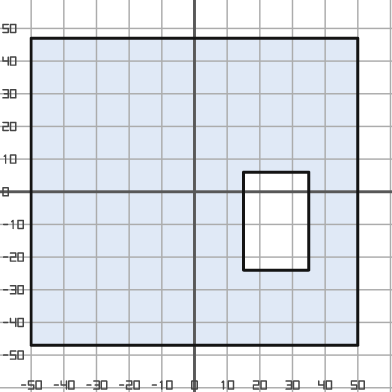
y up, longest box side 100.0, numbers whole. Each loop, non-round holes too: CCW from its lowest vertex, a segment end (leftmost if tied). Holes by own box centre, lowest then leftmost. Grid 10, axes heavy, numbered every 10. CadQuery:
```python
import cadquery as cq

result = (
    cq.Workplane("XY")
    .moveTo(-50.0, -47.0)
    .lineTo(50.0, -47.0)
    .lineTo(50.0, 47.0)
    .lineTo(-50.0, 47.0)
    .close()
    .moveTo(15.0, -24.0)
    .lineTo(35.0, -24.0)
    .lineTo(35.0, 6.0)
    .lineTo(15.0, 6.0)
    .close()
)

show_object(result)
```